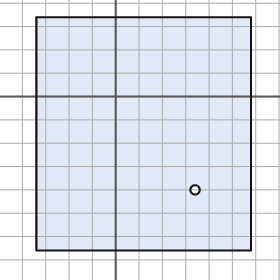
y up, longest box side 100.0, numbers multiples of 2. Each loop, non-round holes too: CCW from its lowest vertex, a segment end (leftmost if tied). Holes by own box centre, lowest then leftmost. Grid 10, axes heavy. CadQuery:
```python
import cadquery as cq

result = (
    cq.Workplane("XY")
    .moveTo(-34.0, -66.0)
    .lineTo(58.0, -66.0)
    .lineTo(58.0, 34.0)
    .lineTo(-34.0, 34.0)
    .close()
    .moveTo(34.0, -40.0)
    .circle(2.0)
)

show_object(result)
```